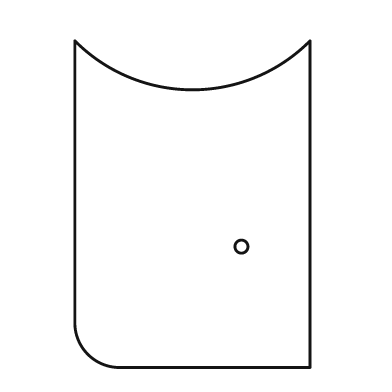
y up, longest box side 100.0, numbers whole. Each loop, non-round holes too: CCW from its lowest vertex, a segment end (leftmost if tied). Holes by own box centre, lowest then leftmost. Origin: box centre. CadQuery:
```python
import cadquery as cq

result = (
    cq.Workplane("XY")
    .moveTo(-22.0, -50.0)
    .lineTo(36.0, -50.0)
    .lineTo(36.0, 50.0)
    .threePointArc((0.0, 35.0), (-36.0, 50.0))
    .lineTo(-36.0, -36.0)
    .threePointArc((-32.0, -46.0), (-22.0, -50.0))
    .close()
    .moveTo(15.0, -13.0)
    .circle(2.0)
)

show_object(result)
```